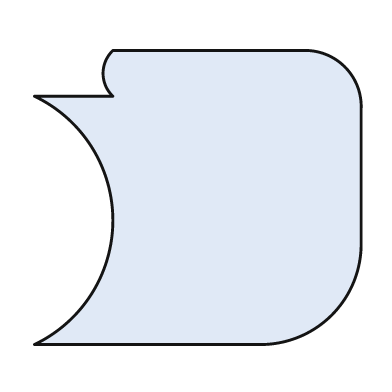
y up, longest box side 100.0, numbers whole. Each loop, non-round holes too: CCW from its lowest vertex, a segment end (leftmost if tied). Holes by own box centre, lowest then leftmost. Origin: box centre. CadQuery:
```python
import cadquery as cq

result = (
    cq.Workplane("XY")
    .moveTo(-50.0, -45.0)
    .lineTo(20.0, -45.0)
    .threePointArc((41.0, -36.0), (50.0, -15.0))
    .lineTo(50.0, 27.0)
    .threePointArc((45.0, 40.0), (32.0, 45.0))
    .lineTo(-26.0, 45.0)
    .threePointArc((-29.0, 38.0), (-26.0, 31.0))
    .lineTo(-50.0, 31.0)
    .threePointArc((-26.0, -7.0), (-50.0, -45.0))
    .close()
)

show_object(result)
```